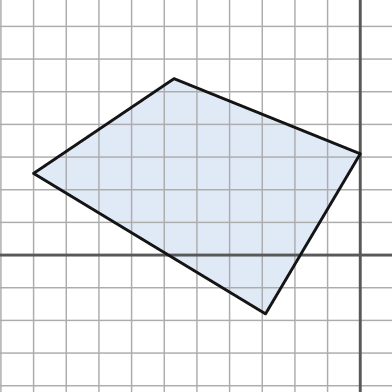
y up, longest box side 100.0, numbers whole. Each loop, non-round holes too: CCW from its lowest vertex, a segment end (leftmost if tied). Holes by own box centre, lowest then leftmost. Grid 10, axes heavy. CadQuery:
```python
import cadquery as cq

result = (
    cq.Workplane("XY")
    .moveTo(-29.0, -18.0)
    .lineTo(0.0, 31.0)
    .lineTo(-57.0, 54.0)
    .lineTo(-100.0, 25.0)
    .close()
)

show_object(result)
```